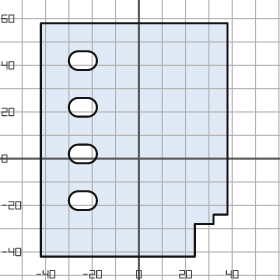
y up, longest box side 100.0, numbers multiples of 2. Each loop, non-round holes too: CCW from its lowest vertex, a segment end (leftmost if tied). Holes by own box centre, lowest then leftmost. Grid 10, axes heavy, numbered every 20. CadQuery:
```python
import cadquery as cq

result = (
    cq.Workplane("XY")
    .moveTo(-42.0, -42.0)
    .lineTo(24.0, -42.0)
    .lineTo(24.0, -28.0)
    .lineTo(32.0, -28.0)
    .lineTo(32.0, -24.0)
    .lineTo(38.0, -24.0)
    .lineTo(38.0, 58.0)
    .lineTo(-42.0, 58.0)
    .close()
    .moveTo(-26.0, -22.0)
    .lineTo(-22.0, -22.0)
    .threePointArc((-18.0, -18.0), (-22.0, -14.0))
    .lineTo(-26.0, -14.0)
    .threePointArc((-30.0, -18.0), (-26.0, -22.0))
    .close()
    .moveTo(-26.0, -2.0)
    .lineTo(-22.0, -2.0)
    .threePointArc((-18.0, 2.0), (-22.0, 6.0))
    .lineTo(-26.0, 6.0)
    .threePointArc((-30.0, 2.0), (-26.0, -2.0))
    .close()
    .moveTo(-26.0, 18.0)
    .lineTo(-22.0, 18.0)
    .threePointArc((-18.0, 22.0), (-22.0, 26.0))
    .lineTo(-26.0, 26.0)
    .threePointArc((-30.0, 22.0), (-26.0, 18.0))
    .close()
    .moveTo(-26.0, 38.0)
    .lineTo(-22.0, 38.0)
    .threePointArc((-18.0, 42.0), (-22.0, 46.0))
    .lineTo(-26.0, 46.0)
    .threePointArc((-30.0, 42.0), (-26.0, 38.0))
    .close()
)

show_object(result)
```